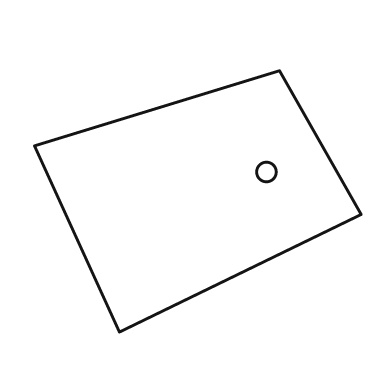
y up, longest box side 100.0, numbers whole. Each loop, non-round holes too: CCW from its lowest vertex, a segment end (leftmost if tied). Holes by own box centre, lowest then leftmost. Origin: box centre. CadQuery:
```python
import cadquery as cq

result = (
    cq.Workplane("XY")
    .moveTo(-24.0, -40.0)
    .lineTo(50.0, -4.0)
    .lineTo(25.0, 40.0)
    .lineTo(-50.0, 17.0)
    .close()
    .moveTo(21.0, 9.0)
    .circle(3.0)
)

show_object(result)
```